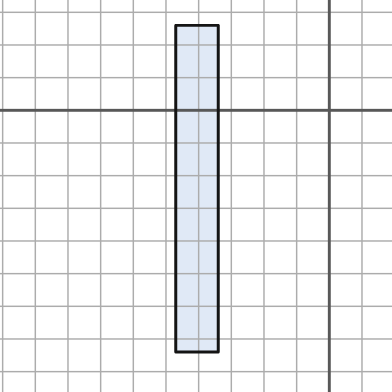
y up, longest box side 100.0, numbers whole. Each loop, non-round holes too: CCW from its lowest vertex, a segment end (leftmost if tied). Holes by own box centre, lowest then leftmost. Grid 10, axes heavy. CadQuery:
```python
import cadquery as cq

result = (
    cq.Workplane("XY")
    .moveTo(-47.0, -74.0)
    .lineTo(-34.0, -74.0)
    .lineTo(-34.0, 26.0)
    .lineTo(-47.0, 26.0)
    .close()
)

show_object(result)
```